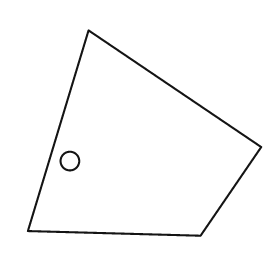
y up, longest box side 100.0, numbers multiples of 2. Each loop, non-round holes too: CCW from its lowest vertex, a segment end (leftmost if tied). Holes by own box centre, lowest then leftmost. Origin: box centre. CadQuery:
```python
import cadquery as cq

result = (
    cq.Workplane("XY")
    .moveTo(24.0, -44.0)
    .lineTo(50.0, -6.0)
    .lineTo(-24.0, 44.0)
    .lineTo(-50.0, -42.0)
    .close()
    .moveTo(-32.0, -12.0)
    .circle(4.0)
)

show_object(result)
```